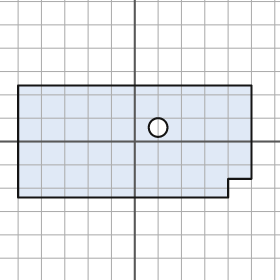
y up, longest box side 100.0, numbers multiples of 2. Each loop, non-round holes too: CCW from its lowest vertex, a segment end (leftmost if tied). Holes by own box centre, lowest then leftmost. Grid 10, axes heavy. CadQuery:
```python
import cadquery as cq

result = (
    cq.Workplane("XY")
    .moveTo(-50.0, -24.0)
    .lineTo(40.0, -24.0)
    .lineTo(40.0, -16.0)
    .lineTo(50.0, -16.0)
    .lineTo(50.0, 24.0)
    .lineTo(-50.0, 24.0)
    .close()
    .moveTo(10.0, 6.0)
    .circle(4.0)
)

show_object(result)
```